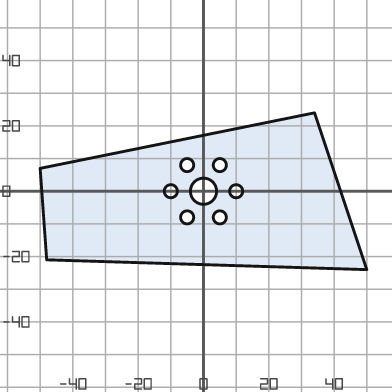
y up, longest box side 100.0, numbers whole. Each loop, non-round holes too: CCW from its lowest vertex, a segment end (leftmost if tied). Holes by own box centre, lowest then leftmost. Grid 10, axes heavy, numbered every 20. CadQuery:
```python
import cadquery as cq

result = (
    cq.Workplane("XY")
    .moveTo(50.0, -24.0)
    .lineTo(34.0, 24.0)
    .lineTo(-50.0, 7.0)
    .lineTo(-48.0, -21.0)
    .close()
    .moveTo(-5.0, -8.0)
    .circle(2.0)
    .moveTo(5.0, -8.0)
    .circle(2.0)
    .moveTo(-10.0, 0.0)
    .circle(2.0)
    .moveTo(0.0, 0.0)
    .circle(4.0)
    .moveTo(10.0, 0.0)
    .circle(2.0)
    .moveTo(-5.0, 8.0)
    .circle(2.0)
    .moveTo(5.0, 8.0)
    .circle(2.0)
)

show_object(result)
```